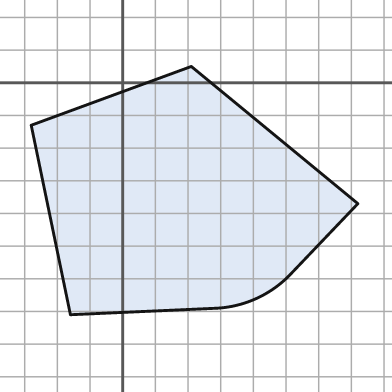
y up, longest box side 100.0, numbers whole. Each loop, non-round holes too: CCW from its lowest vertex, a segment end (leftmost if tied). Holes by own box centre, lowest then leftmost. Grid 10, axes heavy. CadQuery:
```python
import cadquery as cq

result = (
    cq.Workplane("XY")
    .moveTo(-16.0, -71.0)
    .lineTo(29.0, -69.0)
    .threePointArc((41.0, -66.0), (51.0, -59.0))
    .lineTo(72.0, -37.0)
    .lineTo(21.0, 5.0)
    .lineTo(-28.0, -13.0)
    .close()
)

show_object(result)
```